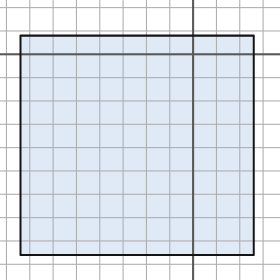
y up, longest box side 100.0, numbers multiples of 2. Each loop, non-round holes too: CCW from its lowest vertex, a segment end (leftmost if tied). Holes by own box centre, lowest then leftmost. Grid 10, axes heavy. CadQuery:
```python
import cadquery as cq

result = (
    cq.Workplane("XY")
    .moveTo(-74.0, -86.0)
    .lineTo(26.0, -86.0)
    .lineTo(26.0, 8.0)
    .lineTo(-74.0, 8.0)
    .close()
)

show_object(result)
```